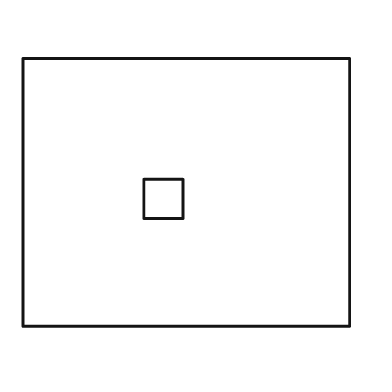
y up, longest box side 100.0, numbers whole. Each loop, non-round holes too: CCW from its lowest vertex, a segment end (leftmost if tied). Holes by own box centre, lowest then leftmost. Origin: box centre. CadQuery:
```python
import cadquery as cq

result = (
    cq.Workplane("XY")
    .moveTo(-50.0, -41.0)
    .lineTo(50.0, -41.0)
    .lineTo(50.0, 41.0)
    .lineTo(-50.0, 41.0)
    .close()
    .moveTo(-13.0, -8.0)
    .lineTo(-1.0, -8.0)
    .lineTo(-1.0, 4.0)
    .lineTo(-13.0, 4.0)
    .close()
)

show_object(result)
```